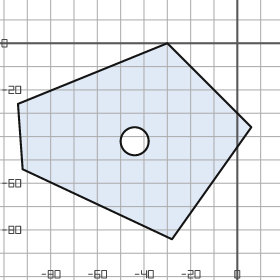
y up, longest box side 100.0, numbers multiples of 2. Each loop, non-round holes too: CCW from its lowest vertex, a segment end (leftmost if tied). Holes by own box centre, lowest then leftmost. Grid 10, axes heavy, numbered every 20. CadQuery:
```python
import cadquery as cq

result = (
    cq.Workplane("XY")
    .moveTo(-28.0, -84.0)
    .lineTo(6.0, -36.0)
    .lineTo(-30.0, 0.0)
    .lineTo(-94.0, -26.0)
    .lineTo(-92.0, -54.0)
    .close()
    .moveTo(-44.0, -42.0)
    .circle(6.0)
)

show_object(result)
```